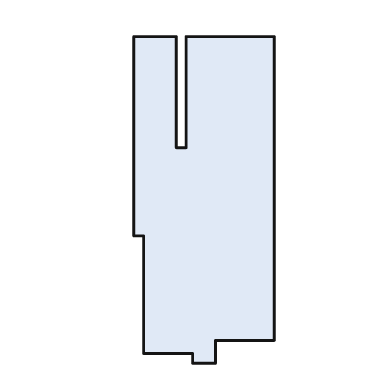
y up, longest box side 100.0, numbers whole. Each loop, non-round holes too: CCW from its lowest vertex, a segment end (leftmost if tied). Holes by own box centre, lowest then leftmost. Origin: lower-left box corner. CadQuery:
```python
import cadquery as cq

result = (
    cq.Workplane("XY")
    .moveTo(18.0, 0.0)
    .lineTo(25.0, 0.0)
    .lineTo(25.0, 7.0)
    .lineTo(43.0, 7.0)
    .lineTo(43.0, 100.0)
    .lineTo(16.0, 100.0)
    .lineTo(16.0, 66.0)
    .lineTo(13.0, 66.0)
    .lineTo(13.0, 100.0)
    .lineTo(0.0, 100.0)
    .lineTo(0.0, 39.0)
    .lineTo(3.0, 39.0)
    .lineTo(3.0, 3.0)
    .lineTo(18.0, 3.0)
    .close()
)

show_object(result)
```